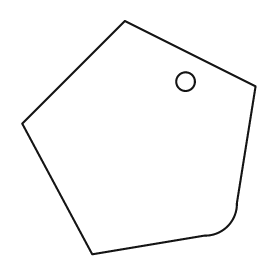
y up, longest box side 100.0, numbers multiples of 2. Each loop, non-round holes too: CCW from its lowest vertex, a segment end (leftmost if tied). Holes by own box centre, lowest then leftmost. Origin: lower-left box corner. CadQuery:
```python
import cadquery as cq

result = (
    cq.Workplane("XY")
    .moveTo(30.0, 0.0)
    .lineTo(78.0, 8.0)
    .threePointArc((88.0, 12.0), (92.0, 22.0))
    .lineTo(100.0, 72.0)
    .lineTo(44.0, 100.0)
    .lineTo(0.0, 56.0)
    .close()
    .moveTo(70.0, 74.0)
    .circle(4.0)
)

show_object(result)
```